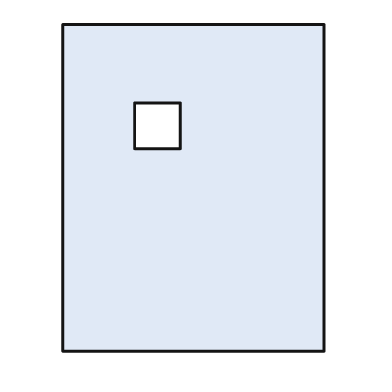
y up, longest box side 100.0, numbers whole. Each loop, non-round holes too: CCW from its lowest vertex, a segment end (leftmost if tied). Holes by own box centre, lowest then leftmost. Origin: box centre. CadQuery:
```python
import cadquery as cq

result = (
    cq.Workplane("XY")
    .moveTo(-40.0, -50.0)
    .lineTo(40.0, -50.0)
    .lineTo(40.0, 50.0)
    .lineTo(-40.0, 50.0)
    .close()
    .moveTo(-18.0, 12.0)
    .lineTo(-4.0, 12.0)
    .lineTo(-4.0, 26.0)
    .lineTo(-18.0, 26.0)
    .close()
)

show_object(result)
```